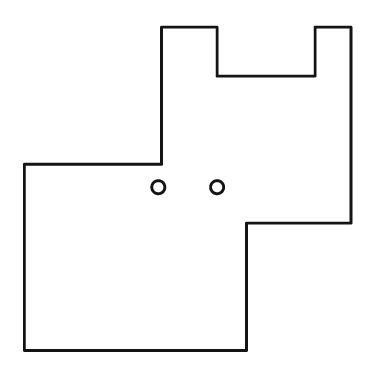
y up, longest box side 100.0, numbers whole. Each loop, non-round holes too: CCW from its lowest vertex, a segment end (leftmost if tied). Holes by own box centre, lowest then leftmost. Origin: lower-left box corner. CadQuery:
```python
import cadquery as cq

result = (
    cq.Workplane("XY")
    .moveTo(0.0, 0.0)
    .lineTo(68.0, 0.0)
    .lineTo(68.0, 39.0)
    .lineTo(100.0, 39.0)
    .lineTo(100.0, 99.0)
    .lineTo(89.0, 99.0)
    .lineTo(89.0, 84.0)
    .lineTo(59.0, 84.0)
    .lineTo(59.0, 99.0)
    .lineTo(42.0, 99.0)
    .lineTo(42.0, 57.0)
    .lineTo(0.0, 57.0)
    .close()
    .moveTo(41.0, 50.0)
    .circle(2.0)
    .moveTo(59.0, 50.0)
    .circle(2.0)
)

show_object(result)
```